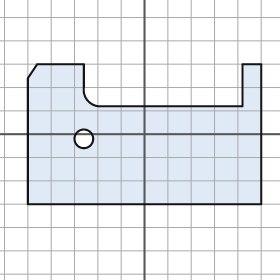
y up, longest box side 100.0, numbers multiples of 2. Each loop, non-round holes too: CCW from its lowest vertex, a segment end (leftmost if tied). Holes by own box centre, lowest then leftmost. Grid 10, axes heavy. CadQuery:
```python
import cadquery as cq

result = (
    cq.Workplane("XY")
    .moveTo(-50.0, -30.0)
    .lineTo(50.0, -30.0)
    .lineTo(50.0, 30.0)
    .lineTo(42.0, 30.0)
    .lineTo(42.0, 12.0)
    .lineTo(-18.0, 12.0)
    .threePointArc((-24.0, 14.0), (-26.0, 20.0))
    .lineTo(-26.0, 30.0)
    .lineTo(-46.0, 30.0)
    .lineTo(-50.0, 24.0)
    .close()
    .moveTo(-26.0, -2.0)
    .circle(4.0)
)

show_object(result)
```